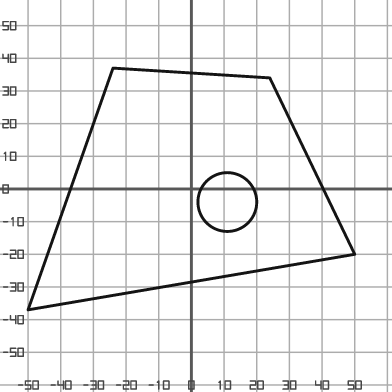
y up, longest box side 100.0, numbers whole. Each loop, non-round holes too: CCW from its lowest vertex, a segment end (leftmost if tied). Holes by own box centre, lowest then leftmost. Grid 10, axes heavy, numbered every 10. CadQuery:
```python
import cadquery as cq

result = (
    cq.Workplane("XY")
    .moveTo(-50.0, -37.0)
    .lineTo(50.0, -20.0)
    .lineTo(24.0, 34.0)
    .lineTo(-24.0, 37.0)
    .close()
    .moveTo(11.0, -4.0)
    .circle(9.0)
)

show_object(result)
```